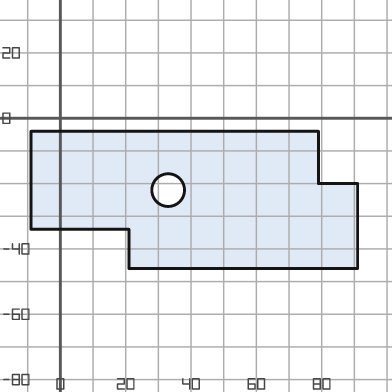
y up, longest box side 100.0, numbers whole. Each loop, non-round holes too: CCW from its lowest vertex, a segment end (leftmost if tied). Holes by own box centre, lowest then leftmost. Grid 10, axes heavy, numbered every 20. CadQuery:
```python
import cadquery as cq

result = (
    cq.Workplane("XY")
    .moveTo(21.0, -46.0)
    .lineTo(91.0, -46.0)
    .lineTo(91.0, -20.0)
    .lineTo(79.0, -20.0)
    .lineTo(79.0, -4.0)
    .lineTo(-9.0, -4.0)
    .lineTo(-9.0, -34.0)
    .lineTo(21.0, -34.0)
    .close()
    .moveTo(33.0, -22.0)
    .circle(5.0)
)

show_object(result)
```